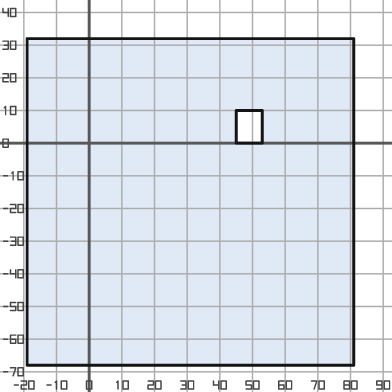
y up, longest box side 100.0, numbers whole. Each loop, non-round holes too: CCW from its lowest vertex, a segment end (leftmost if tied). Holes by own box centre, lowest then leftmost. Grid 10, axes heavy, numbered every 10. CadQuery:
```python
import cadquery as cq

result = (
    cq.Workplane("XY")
    .moveTo(-19.0, -68.0)
    .lineTo(81.0, -68.0)
    .lineTo(81.0, 32.0)
    .lineTo(-19.0, 32.0)
    .close()
    .moveTo(45.0, 0.0)
    .lineTo(53.0, 0.0)
    .lineTo(53.0, 10.0)
    .lineTo(45.0, 10.0)
    .close()
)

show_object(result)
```